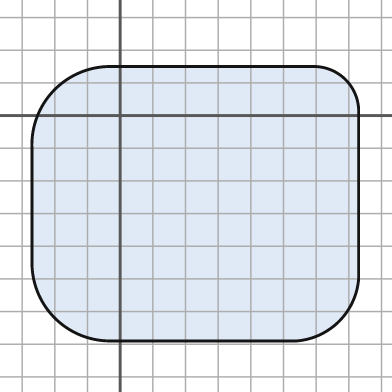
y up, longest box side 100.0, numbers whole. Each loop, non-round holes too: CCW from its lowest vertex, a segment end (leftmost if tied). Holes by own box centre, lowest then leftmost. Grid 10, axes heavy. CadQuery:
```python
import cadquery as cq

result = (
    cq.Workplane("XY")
    .moveTo(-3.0, -69.0)
    .lineTo(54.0, -69.0)
    .threePointArc((67.0, -63.0), (73.0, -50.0))
    .lineTo(73.0, 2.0)
    .threePointArc((69.0, 11.0), (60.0, 15.0))
    .lineTo(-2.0, 15.0)
    .threePointArc((-20.0, 8.0), (-27.0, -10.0))
    .lineTo(-27.0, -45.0)
    .threePointArc((-20.0, -62.0), (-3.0, -69.0))
    .close()
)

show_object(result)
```